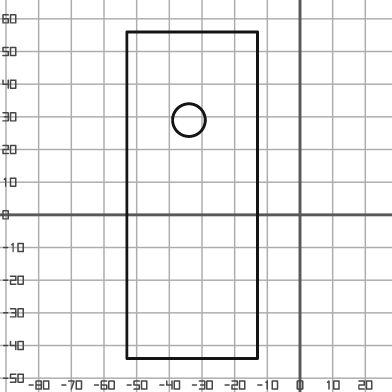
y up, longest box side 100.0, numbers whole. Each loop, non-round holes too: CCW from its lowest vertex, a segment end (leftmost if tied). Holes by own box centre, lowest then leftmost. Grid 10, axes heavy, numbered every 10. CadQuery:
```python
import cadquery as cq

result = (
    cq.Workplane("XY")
    .moveTo(-53.0, -44.0)
    .lineTo(-13.0, -44.0)
    .lineTo(-13.0, 56.0)
    .lineTo(-53.0, 56.0)
    .close()
    .moveTo(-34.0, 29.0)
    .circle(5.0)
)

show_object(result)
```